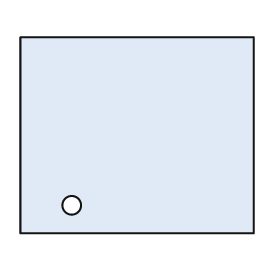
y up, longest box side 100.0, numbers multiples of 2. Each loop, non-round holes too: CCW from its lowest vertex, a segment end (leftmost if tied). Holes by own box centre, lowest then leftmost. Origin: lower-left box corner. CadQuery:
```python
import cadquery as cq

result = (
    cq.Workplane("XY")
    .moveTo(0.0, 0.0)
    .lineTo(100.0, 0.0)
    .lineTo(100.0, 84.0)
    .lineTo(0.0, 84.0)
    .close()
    .moveTo(22.0, 12.0)
    .circle(4.0)
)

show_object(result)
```